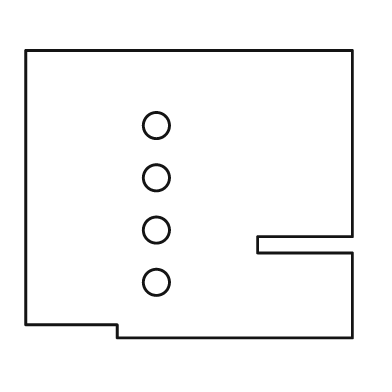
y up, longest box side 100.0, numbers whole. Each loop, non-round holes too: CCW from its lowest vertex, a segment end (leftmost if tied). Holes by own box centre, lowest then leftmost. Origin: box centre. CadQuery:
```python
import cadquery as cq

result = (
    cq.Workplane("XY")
    .moveTo(-22.0, -44.0)
    .lineTo(50.0, -44.0)
    .lineTo(50.0, -18.0)
    .lineTo(21.0, -18.0)
    .lineTo(21.0, -13.0)
    .lineTo(50.0, -13.0)
    .lineTo(50.0, 44.0)
    .lineTo(-50.0, 44.0)
    .lineTo(-50.0, -40.0)
    .lineTo(-22.0, -40.0)
    .close()
    .moveTo(-10.0, -27.0)
    .circle(4.0)
    .moveTo(-10.0, -11.0)
    .circle(4.0)
    .moveTo(-10.0, 5.0)
    .circle(4.0)
    .moveTo(-10.0, 21.0)
    .circle(4.0)
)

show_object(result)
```